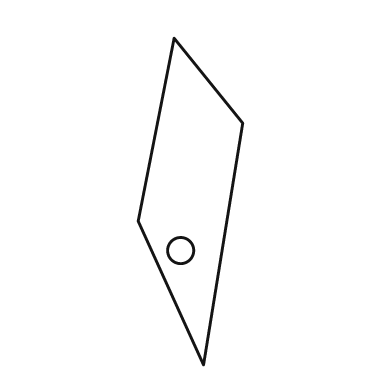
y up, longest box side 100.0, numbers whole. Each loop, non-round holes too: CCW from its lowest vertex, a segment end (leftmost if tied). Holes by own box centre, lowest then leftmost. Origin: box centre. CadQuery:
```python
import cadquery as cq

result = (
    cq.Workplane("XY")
    .moveTo(4.0, -50.0)
    .lineTo(16.0, 24.0)
    .lineTo(-5.0, 50.0)
    .lineTo(-16.0, -6.0)
    .close()
    .moveTo(-3.0, -15.0)
    .circle(4.0)
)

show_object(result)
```